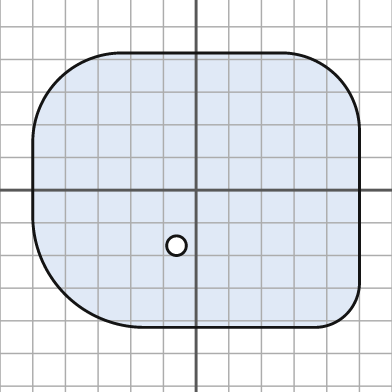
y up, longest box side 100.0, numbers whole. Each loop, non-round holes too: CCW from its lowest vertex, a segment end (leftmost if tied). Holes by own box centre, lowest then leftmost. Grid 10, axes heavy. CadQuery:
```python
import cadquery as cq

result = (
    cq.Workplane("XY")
    .moveTo(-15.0, -42.0)
    .lineTo(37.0, -42.0)
    .threePointArc((46.0, -38.0), (50.0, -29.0))
    .lineTo(50.0, 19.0)
    .threePointArc((43.0, 35.0), (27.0, 42.0))
    .lineTo(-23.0, 42.0)
    .threePointArc((-42.0, 34.0), (-50.0, 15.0))
    .lineTo(-50.0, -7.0)
    .threePointArc((-40.0, -32.0), (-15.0, -42.0))
    .close()
    .moveTo(-6.0, -17.0)
    .circle(3.0)
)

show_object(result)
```